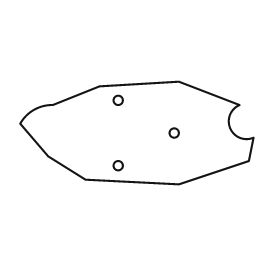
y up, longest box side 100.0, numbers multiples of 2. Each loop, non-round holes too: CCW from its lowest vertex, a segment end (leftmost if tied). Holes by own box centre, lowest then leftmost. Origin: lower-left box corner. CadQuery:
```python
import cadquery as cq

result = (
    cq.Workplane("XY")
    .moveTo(68.0, 0.0)
    .lineTo(98.0, 10.0)
    .lineTo(100.0, 20.0)
    .threePointArc((90.0, 24.0), (94.0, 34.0))
    .lineTo(68.0, 44.0)
    .lineTo(34.0, 42.0)
    .lineTo(14.0, 34.0)
    .threePointArc((6.0, 32.0), (0.0, 26.0))
    .lineTo(12.0, 12.0)
    .lineTo(28.0, 2.0)
    .close()
    .moveTo(42.0, 8.0)
    .circle(2.0)
    .moveTo(66.0, 22.0)
    .circle(2.0)
    .moveTo(42.0, 36.0)
    .circle(2.0)
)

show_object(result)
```